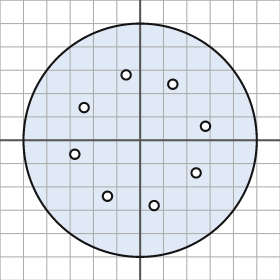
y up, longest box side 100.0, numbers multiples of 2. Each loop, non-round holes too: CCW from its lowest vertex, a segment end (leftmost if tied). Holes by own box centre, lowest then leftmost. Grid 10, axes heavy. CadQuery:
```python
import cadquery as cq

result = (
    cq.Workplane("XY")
    .moveTo(0.0, 0.0)
    .circle(50.0)
    .moveTo(6.0, -28.0)
    .circle(2.0)
    .moveTo(-14.0, -24.0)
    .circle(2.0)
    .moveTo(24.0, -14.0)
    .circle(2.0)
    .moveTo(-28.0, -6.0)
    .circle(2.0)
    .moveTo(28.0, 6.0)
    .circle(2.0)
    .moveTo(-24.0, 14.0)
    .circle(2.0)
    .moveTo(14.0, 24.0)
    .circle(2.0)
    .moveTo(-6.0, 28.0)
    .circle(2.0)
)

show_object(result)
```